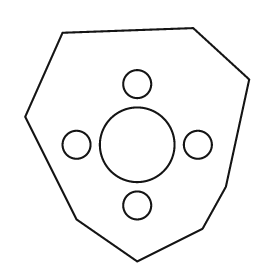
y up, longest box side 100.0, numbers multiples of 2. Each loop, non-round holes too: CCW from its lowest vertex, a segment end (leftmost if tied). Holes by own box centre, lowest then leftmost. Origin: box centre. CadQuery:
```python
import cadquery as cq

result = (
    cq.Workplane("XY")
    .moveTo(0.0, -50.0)
    .lineTo(28.0, -36.0)
    .lineTo(38.0, -18.0)
    .lineTo(48.0, 28.0)
    .lineTo(24.0, 50.0)
    .lineTo(-32.0, 48.0)
    .lineTo(-48.0, 12.0)
    .lineTo(-26.0, -32.0)
    .close()
    .moveTo(0.0, -26.0)
    .circle(6.0)
    .moveTo(-26.0, 0.0)
    .circle(6.0)
    .moveTo(0.0, 0.0)
    .circle(16.0)
    .moveTo(26.0, 0.0)
    .circle(6.0)
    .moveTo(0.0, 26.0)
    .circle(6.0)
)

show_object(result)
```